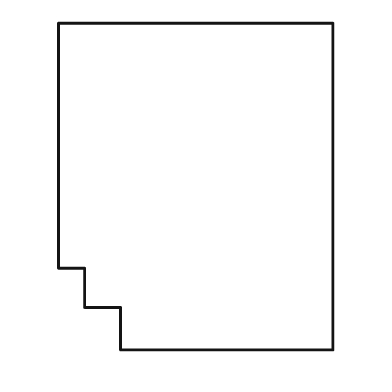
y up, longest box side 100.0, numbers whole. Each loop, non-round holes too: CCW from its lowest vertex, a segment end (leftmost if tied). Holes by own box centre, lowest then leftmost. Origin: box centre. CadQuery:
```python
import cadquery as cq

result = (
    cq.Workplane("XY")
    .moveTo(-23.0, -50.0)
    .lineTo(42.0, -50.0)
    .lineTo(42.0, 50.0)
    .lineTo(-42.0, 50.0)
    .lineTo(-42.0, -25.0)
    .lineTo(-34.0, -25.0)
    .lineTo(-34.0, -37.0)
    .lineTo(-23.0, -37.0)
    .close()
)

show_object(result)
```